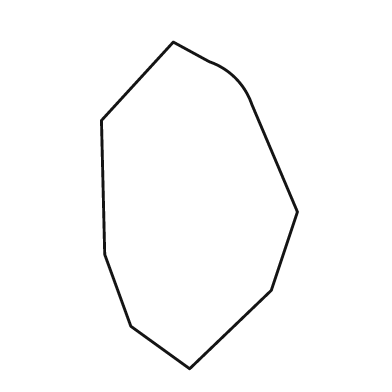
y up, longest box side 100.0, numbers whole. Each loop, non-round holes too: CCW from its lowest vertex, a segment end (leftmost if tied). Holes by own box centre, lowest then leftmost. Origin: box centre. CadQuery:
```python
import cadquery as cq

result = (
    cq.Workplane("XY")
    .moveTo(-3.0, -50.0)
    .lineTo(22.0, -26.0)
    .lineTo(30.0, -2.0)
    .lineTo(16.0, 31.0)
    .threePointArc((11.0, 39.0), (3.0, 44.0))
    .lineTo(-8.0, 50.0)
    .lineTo(-30.0, 26.0)
    .lineTo(-29.0, -15.0)
    .lineTo(-21.0, -37.0)
    .close()
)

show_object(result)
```